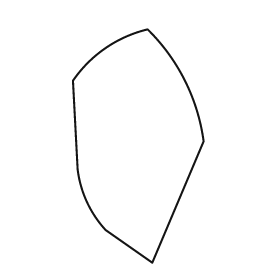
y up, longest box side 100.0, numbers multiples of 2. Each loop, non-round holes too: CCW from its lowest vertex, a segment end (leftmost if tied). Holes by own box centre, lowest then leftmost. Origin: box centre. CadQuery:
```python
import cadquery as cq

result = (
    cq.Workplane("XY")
    .moveTo(6.0, -50.0)
    .lineTo(28.0, 2.0)
    .threePointArc((20.0, 28.0), (4.0, 50.0))
    .threePointArc((-14.0, 42.0), (-28.0, 28.0))
    .lineTo(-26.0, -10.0)
    .threePointArc((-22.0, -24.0), (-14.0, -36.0))
    .close()
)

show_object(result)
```